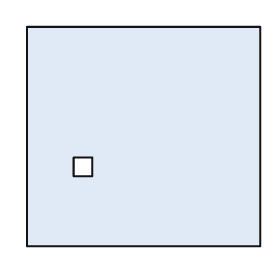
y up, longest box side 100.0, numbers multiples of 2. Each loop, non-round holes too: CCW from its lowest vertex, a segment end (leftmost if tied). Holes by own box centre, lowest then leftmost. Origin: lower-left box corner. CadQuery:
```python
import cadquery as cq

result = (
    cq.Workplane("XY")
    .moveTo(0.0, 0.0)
    .lineTo(100.0, 0.0)
    .lineTo(100.0, 94.0)
    .lineTo(0.0, 94.0)
    .close()
    .moveTo(20.0, 30.0)
    .lineTo(28.0, 30.0)
    .lineTo(28.0, 38.0)
    .lineTo(20.0, 38.0)
    .close()
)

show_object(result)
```